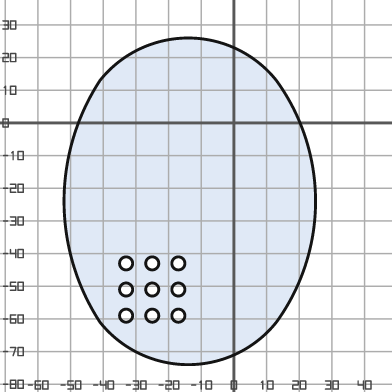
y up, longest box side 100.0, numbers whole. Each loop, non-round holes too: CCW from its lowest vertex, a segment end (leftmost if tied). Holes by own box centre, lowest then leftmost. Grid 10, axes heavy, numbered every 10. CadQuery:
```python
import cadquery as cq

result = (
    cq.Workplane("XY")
    .moveTo(-41.0, -61.0)
    .threePointArc((-14.0, -74.0), (13.0, -61.0))
    .threePointArc((25.0, -24.0), (13.0, 13.0))
    .threePointArc((-14.0, 26.0), (-41.0, 13.0))
    .threePointArc((-52.0, -24.0), (-41.0, -61.0))
    .close()
    .moveTo(-33.0, -59.0)
    .circle(2.0)
    .moveTo(-25.0, -59.0)
    .circle(2.0)
    .moveTo(-17.0, -59.0)
    .circle(2.0)
    .moveTo(-33.0, -51.0)
    .circle(2.0)
    .moveTo(-25.0, -51.0)
    .circle(2.0)
    .moveTo(-17.0, -51.0)
    .circle(2.0)
    .moveTo(-33.0, -43.0)
    .circle(2.0)
    .moveTo(-25.0, -43.0)
    .circle(2.0)
    .moveTo(-17.0, -43.0)
    .circle(2.0)
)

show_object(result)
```